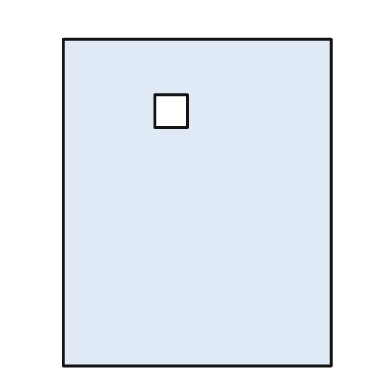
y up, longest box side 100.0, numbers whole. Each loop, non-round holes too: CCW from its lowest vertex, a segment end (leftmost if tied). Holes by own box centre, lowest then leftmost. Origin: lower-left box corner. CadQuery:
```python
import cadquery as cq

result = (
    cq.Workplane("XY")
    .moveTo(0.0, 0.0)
    .lineTo(82.0, 0.0)
    .lineTo(82.0, 100.0)
    .lineTo(0.0, 100.0)
    .close()
    .moveTo(28.0, 73.0)
    .lineTo(38.0, 73.0)
    .lineTo(38.0, 83.0)
    .lineTo(28.0, 83.0)
    .close()
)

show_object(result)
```